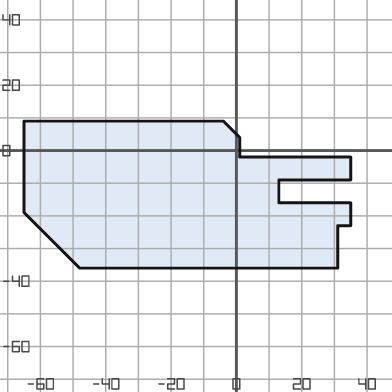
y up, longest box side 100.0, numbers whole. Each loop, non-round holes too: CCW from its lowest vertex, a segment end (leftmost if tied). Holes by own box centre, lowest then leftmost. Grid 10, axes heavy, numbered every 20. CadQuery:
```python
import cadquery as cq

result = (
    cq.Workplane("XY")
    .moveTo(-48.0, -36.0)
    .lineTo(31.0, -36.0)
    .lineTo(31.0, -23.0)
    .lineTo(35.0, -23.0)
    .lineTo(35.0, -16.0)
    .lineTo(13.0, -16.0)
    .lineTo(13.0, -9.0)
    .lineTo(35.0, -9.0)
    .lineTo(35.0, -2.0)
    .lineTo(1.0, -2.0)
    .lineTo(1.0, 4.0)
    .lineTo(-4.0, 9.0)
    .lineTo(-65.0, 9.0)
    .lineTo(-65.0, -19.0)
    .close()
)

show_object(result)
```